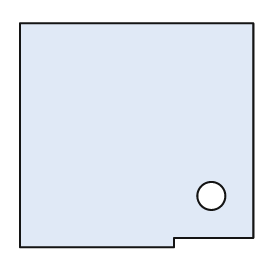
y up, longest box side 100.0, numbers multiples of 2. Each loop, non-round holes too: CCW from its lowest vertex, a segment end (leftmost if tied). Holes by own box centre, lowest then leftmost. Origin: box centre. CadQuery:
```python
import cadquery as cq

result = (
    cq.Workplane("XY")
    .moveTo(-50.0, -48.0)
    .lineTo(16.0, -48.0)
    .lineTo(16.0, -44.0)
    .lineTo(50.0, -44.0)
    .lineTo(50.0, 48.0)
    .lineTo(-50.0, 48.0)
    .close()
    .moveTo(32.0, -26.0)
    .circle(6.0)
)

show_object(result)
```